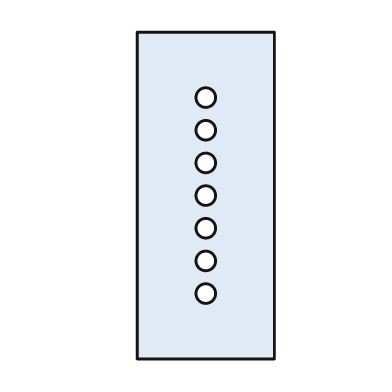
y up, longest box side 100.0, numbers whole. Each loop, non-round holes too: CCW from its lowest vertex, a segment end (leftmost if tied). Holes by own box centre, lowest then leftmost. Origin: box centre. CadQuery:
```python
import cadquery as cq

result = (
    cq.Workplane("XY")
    .moveTo(-21.0, -50.0)
    .lineTo(21.0, -50.0)
    .lineTo(21.0, 50.0)
    .lineTo(-21.0, 50.0)
    .close()
    .moveTo(0.0, -30.0)
    .circle(3.0)
    .moveTo(0.0, -20.0)
    .circle(3.0)
    .moveTo(0.0, -10.0)
    .circle(3.0)
    .moveTo(0.0, 0.0)
    .circle(3.0)
    .moveTo(0.0, 10.0)
    .circle(3.0)
    .moveTo(0.0, 20.0)
    .circle(3.0)
    .moveTo(0.0, 30.0)
    .circle(3.0)
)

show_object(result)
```